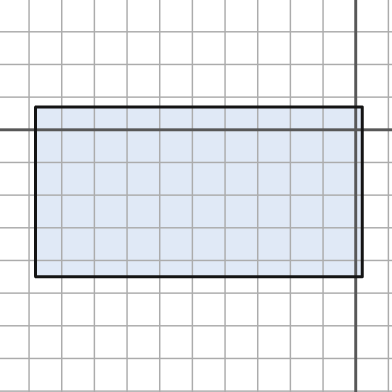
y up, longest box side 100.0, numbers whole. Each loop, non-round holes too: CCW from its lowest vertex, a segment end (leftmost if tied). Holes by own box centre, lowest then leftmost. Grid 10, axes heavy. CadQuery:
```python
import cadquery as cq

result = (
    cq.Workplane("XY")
    .moveTo(-98.0, -45.0)
    .lineTo(2.0, -45.0)
    .lineTo(2.0, 7.0)
    .lineTo(-98.0, 7.0)
    .close()
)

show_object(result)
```